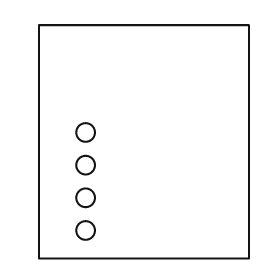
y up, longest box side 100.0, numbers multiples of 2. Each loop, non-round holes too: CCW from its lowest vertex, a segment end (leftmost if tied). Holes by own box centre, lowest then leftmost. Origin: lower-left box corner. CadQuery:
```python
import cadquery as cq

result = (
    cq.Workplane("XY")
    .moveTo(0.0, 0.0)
    .lineTo(90.0, 0.0)
    .lineTo(90.0, 100.0)
    .lineTo(0.0, 100.0)
    .close()
    .moveTo(20.0, 12.0)
    .circle(4.0)
    .moveTo(20.0, 26.0)
    .circle(4.0)
    .moveTo(20.0, 40.0)
    .circle(4.0)
    .moveTo(20.0, 54.0)
    .circle(4.0)
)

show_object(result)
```